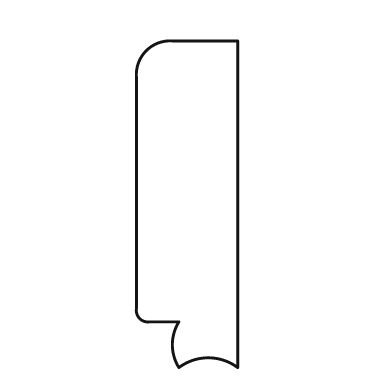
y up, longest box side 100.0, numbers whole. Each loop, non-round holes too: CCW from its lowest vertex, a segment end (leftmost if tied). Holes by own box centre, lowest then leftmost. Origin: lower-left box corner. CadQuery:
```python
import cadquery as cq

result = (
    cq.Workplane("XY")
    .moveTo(13.0, 0.0)
    .threePointArc((22.0, 3.0), (31.0, 0.0))
    .lineTo(31.0, 100.0)
    .lineTo(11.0, 100.0)
    .threePointArc((3.0, 97.0), (0.0, 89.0))
    .lineTo(0.0, 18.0)
    .threePointArc((1.0, 15.0), (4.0, 14.0))
    .lineTo(13.0, 14.0)
    .threePointArc((11.0, 7.0), (13.0, 0.0))
    .close()
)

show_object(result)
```